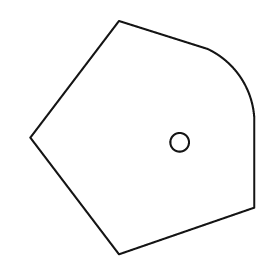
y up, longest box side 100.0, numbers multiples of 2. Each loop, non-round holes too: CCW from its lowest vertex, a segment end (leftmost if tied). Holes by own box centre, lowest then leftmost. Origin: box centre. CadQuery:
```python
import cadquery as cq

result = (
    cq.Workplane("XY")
    .moveTo(-10.0, -50.0)
    .lineTo(48.0, -30.0)
    .lineTo(48.0, 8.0)
    .threePointArc((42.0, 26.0), (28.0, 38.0))
    .lineTo(-10.0, 50.0)
    .lineTo(-48.0, 0.0)
    .close()
    .moveTo(16.0, -2.0)
    .circle(4.0)
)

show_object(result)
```